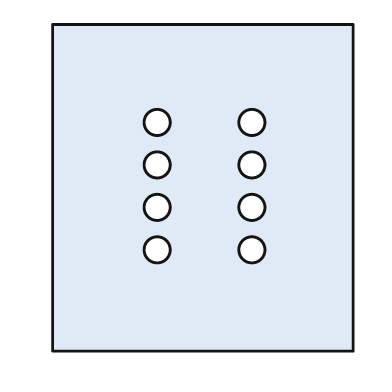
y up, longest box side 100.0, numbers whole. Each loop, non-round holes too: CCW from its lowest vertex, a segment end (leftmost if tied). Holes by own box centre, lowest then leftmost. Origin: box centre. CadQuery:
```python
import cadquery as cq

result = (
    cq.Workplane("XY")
    .moveTo(-46.0, -50.0)
    .lineTo(46.0, -50.0)
    .lineTo(46.0, 50.0)
    .lineTo(-46.0, 50.0)
    .close()
    .moveTo(-14.0, -19.0)
    .circle(4.0)
    .moveTo(15.0, -19.0)
    .circle(4.0)
    .moveTo(-14.0, -6.0)
    .circle(4.0)
    .moveTo(15.0, -6.0)
    .circle(4.0)
    .moveTo(-14.0, 7.0)
    .circle(4.0)
    .moveTo(15.0, 7.0)
    .circle(4.0)
    .moveTo(-14.0, 20.0)
    .circle(4.0)
    .moveTo(15.0, 20.0)
    .circle(4.0)
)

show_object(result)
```